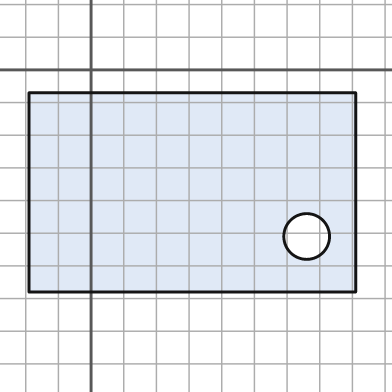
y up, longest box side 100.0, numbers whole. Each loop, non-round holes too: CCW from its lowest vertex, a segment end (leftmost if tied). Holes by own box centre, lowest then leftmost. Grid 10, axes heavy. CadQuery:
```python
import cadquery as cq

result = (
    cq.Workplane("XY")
    .moveTo(-19.0, -68.0)
    .lineTo(81.0, -68.0)
    .lineTo(81.0, -7.0)
    .lineTo(-19.0, -7.0)
    .close()
    .moveTo(66.0, -51.0)
    .circle(7.0)
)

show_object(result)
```